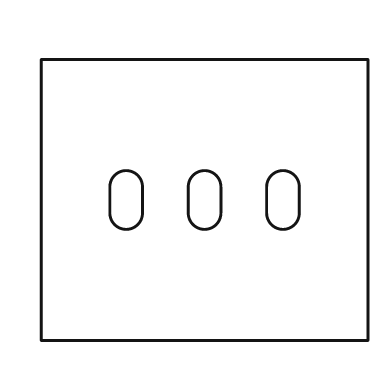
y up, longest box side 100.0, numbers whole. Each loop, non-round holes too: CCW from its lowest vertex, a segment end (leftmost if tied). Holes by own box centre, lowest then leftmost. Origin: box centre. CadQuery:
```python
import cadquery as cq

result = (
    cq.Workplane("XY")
    .moveTo(-50.0, -43.0)
    .lineTo(50.0, -43.0)
    .lineTo(50.0, 43.0)
    .lineTo(-50.0, 43.0)
    .close()
    .moveTo(-29.0, -4.0)
    .threePointArc((-24.0, -9.0), (-19.0, -4.0))
    .lineTo(-19.0, 4.0)
    .threePointArc((-24.0, 9.0), (-29.0, 4.0))
    .close()
    .moveTo(-5.0, -4.0)
    .threePointArc((0.0, -9.0), (5.0, -4.0))
    .lineTo(5.0, 4.0)
    .threePointArc((0.0, 9.0), (-5.0, 4.0))
    .close()
    .moveTo(19.0, -4.0)
    .threePointArc((24.0, -9.0), (29.0, -4.0))
    .lineTo(29.0, 4.0)
    .threePointArc((24.0, 9.0), (19.0, 4.0))
    .close()
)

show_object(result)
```